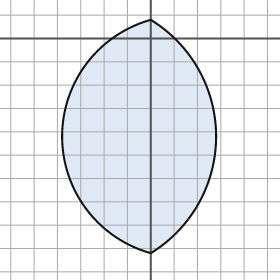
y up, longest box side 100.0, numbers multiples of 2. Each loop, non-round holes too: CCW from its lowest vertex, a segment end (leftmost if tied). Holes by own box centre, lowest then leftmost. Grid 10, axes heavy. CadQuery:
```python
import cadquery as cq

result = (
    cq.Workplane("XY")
    .moveTo(0.0, -92.0)
    .threePointArc((28.0, -42.0), (0.0, 8.0))
    .threePointArc((-38.0, -42.0), (0.0, -92.0))
    .close()
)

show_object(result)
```